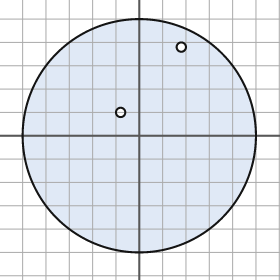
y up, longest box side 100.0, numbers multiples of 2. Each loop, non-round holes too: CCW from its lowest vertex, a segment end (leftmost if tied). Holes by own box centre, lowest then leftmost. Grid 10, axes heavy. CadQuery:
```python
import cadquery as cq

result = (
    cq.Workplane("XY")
    .moveTo(0.0, 0.0)
    .circle(50.0)
    .moveTo(-8.0, 10.0)
    .circle(2.0)
    .moveTo(18.0, 38.0)
    .circle(2.0)
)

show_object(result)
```